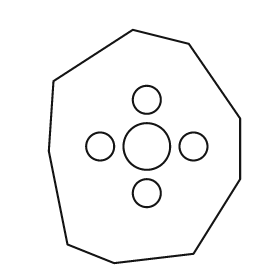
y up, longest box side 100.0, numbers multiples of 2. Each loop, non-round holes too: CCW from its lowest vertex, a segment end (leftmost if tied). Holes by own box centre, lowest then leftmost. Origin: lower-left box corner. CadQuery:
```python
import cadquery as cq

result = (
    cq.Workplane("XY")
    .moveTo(28.0, 0.0)
    .lineTo(62.0, 4.0)
    .lineTo(82.0, 36.0)
    .lineTo(82.0, 62.0)
    .lineTo(60.0, 94.0)
    .lineTo(36.0, 100.0)
    .lineTo(2.0, 78.0)
    .lineTo(0.0, 48.0)
    .lineTo(8.0, 8.0)
    .close()
    .moveTo(42.0, 30.0)
    .circle(6.0)
    .moveTo(22.0, 50.0)
    .circle(6.0)
    .moveTo(42.0, 50.0)
    .circle(10.0)
    .moveTo(62.0, 50.0)
    .circle(6.0)
    .moveTo(42.0, 70.0)
    .circle(6.0)
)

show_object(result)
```